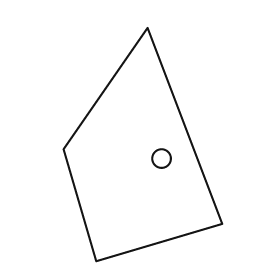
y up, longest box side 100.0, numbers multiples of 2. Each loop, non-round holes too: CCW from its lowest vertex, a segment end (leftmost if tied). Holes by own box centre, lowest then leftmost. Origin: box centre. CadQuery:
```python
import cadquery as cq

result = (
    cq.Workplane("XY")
    .moveTo(-20.0, -50.0)
    .lineTo(34.0, -34.0)
    .lineTo(2.0, 50.0)
    .lineTo(-34.0, -2.0)
    .close()
    .moveTo(8.0, -6.0)
    .circle(4.0)
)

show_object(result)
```